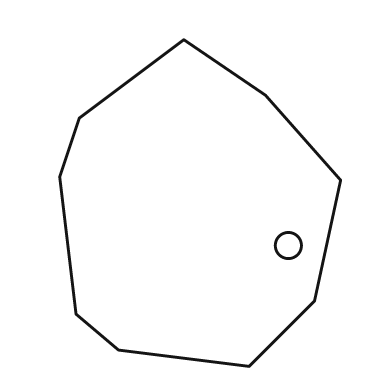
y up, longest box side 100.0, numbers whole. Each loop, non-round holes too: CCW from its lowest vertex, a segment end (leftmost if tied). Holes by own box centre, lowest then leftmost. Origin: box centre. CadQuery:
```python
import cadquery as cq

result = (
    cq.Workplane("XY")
    .moveTo(15.0, -50.0)
    .lineTo(35.0, -30.0)
    .lineTo(43.0, 7.0)
    .lineTo(20.0, 33.0)
    .lineTo(-5.0, 50.0)
    .lineTo(-37.0, 26.0)
    .lineTo(-43.0, 8.0)
    .lineTo(-38.0, -34.0)
    .lineTo(-25.0, -45.0)
    .close()
    .moveTo(27.0, -13.0)
    .circle(4.0)
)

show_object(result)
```